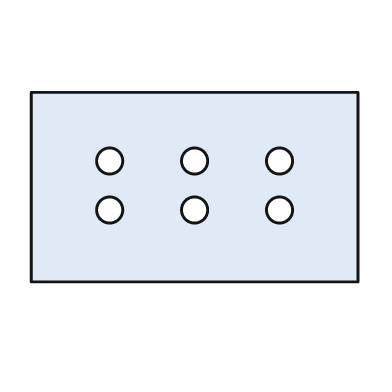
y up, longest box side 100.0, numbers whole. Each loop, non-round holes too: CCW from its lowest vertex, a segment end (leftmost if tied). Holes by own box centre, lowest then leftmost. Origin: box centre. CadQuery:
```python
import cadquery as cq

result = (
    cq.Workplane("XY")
    .moveTo(-50.0, -29.0)
    .lineTo(50.0, -29.0)
    .lineTo(50.0, 29.0)
    .lineTo(-50.0, 29.0)
    .close()
    .moveTo(-26.0, -7.0)
    .circle(4.0)
    .moveTo(0.0, -7.0)
    .circle(4.0)
    .moveTo(26.0, -7.0)
    .circle(4.0)
    .moveTo(-26.0, 8.0)
    .circle(4.0)
    .moveTo(0.0, 8.0)
    .circle(4.0)
    .moveTo(26.0, 8.0)
    .circle(4.0)
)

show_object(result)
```